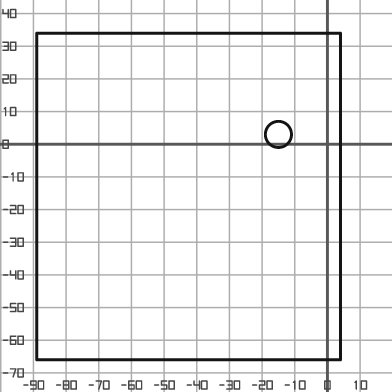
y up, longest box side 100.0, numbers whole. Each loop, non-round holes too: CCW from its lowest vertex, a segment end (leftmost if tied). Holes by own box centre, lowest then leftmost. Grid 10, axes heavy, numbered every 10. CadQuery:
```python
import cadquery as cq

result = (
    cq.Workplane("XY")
    .moveTo(-89.0, -66.0)
    .lineTo(4.0, -66.0)
    .lineTo(4.0, 34.0)
    .lineTo(-89.0, 34.0)
    .close()
    .moveTo(-15.0, 3.0)
    .circle(4.0)
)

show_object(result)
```